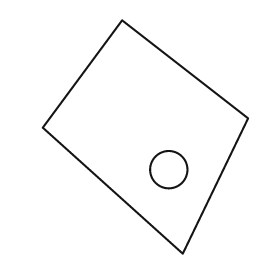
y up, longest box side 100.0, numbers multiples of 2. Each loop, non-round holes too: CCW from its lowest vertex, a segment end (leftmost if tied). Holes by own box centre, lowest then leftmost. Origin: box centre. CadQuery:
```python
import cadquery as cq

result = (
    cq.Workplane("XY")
    .moveTo(16.0, -50.0)
    .lineTo(44.0, 8.0)
    .lineTo(-10.0, 50.0)
    .lineTo(-44.0, 4.0)
    .close()
    .moveTo(10.0, -14.0)
    .circle(8.0)
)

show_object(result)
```